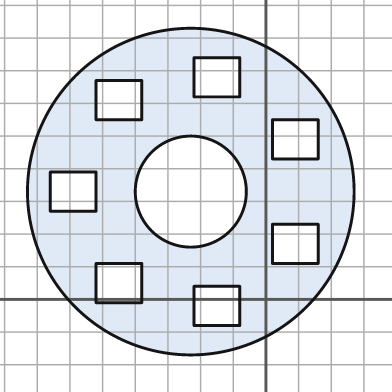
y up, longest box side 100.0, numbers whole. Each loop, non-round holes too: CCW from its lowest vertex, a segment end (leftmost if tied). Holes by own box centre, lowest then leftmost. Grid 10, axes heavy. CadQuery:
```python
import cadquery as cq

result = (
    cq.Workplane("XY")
    .moveTo(-23.0, 33.0)
    .circle(50.0)
    .moveTo(-22.0, -8.0)
    .lineTo(-8.0, -8.0)
    .lineTo(-8.0, 4.0)
    .lineTo(-22.0, 4.0)
    .close()
    .moveTo(-52.0, -1.0)
    .lineTo(-38.0, -1.0)
    .lineTo(-38.0, 11.0)
    .lineTo(-52.0, 11.0)
    .close()
    .moveTo(2.0, 11.0)
    .lineTo(16.0, 11.0)
    .lineTo(16.0, 23.0)
    .lineTo(2.0, 23.0)
    .close()
    .moveTo(-66.0, 27.0)
    .lineTo(-52.0, 27.0)
    .lineTo(-52.0, 39.0)
    .lineTo(-66.0, 39.0)
    .close()
    .moveTo(-23.0, 33.0)
    .circle(17.0)
    .moveTo(2.0, 43.0)
    .lineTo(16.0, 43.0)
    .lineTo(16.0, 55.0)
    .lineTo(2.0, 55.0)
    .close()
    .moveTo(-52.0, 55.0)
    .lineTo(-38.0, 55.0)
    .lineTo(-38.0, 67.0)
    .lineTo(-52.0, 67.0)
    .close()
    .moveTo(-22.0, 62.0)
    .lineTo(-8.0, 62.0)
    .lineTo(-8.0, 74.0)
    .lineTo(-22.0, 74.0)
    .close()
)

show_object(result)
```